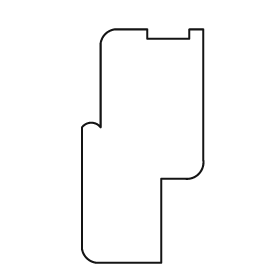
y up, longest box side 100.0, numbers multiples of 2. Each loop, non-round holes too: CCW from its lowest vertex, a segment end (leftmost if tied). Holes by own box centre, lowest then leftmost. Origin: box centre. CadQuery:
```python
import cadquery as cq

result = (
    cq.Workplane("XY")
    .moveTo(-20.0, -50.0)
    .lineTo(8.0, -50.0)
    .lineTo(8.0, -14.0)
    .lineTo(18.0, -14.0)
    .threePointArc((24.0, -12.0), (26.0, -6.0))
    .lineTo(26.0, 50.0)
    .lineTo(20.0, 50.0)
    .lineTo(20.0, 46.0)
    .lineTo(2.0, 46.0)
    .lineTo(2.0, 50.0)
    .lineTo(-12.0, 50.0)
    .threePointArc((-16.0, 48.0), (-18.0, 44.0))
    .lineTo(-18.0, 8.0)
    .threePointArc((-22.0, 10.0), (-26.0, 8.0))
    .lineTo(-26.0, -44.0)
    .threePointArc((-24.0, -48.0), (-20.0, -50.0))
    .close()
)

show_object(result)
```